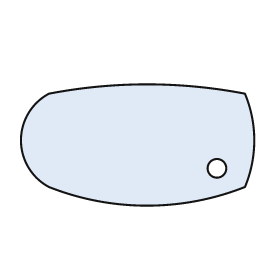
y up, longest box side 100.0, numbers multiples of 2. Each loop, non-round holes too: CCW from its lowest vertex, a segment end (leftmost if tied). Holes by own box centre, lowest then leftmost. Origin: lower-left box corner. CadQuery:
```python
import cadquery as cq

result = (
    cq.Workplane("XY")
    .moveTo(12.0, 8.0)
    .threePointArc((54.0, 0.0), (96.0, 8.0))
    .threePointArc((100.0, 28.0), (96.0, 48.0))
    .threePointArc((54.0, 52.0), (12.0, 48.0))
    .threePointArc((0.0, 28.0), (12.0, 8.0))
    .close()
    .moveTo(84.0, 16.0)
    .circle(4.0)
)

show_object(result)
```